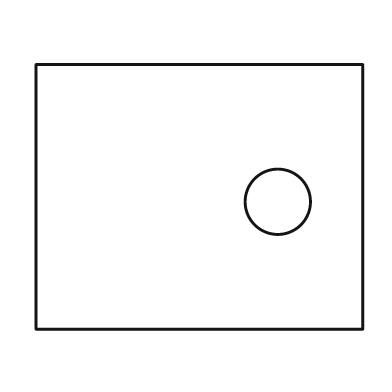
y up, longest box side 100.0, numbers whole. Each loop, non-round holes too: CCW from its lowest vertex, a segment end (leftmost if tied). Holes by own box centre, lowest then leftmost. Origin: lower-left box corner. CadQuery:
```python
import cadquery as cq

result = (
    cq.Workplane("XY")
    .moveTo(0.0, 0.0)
    .lineTo(100.0, 0.0)
    .lineTo(100.0, 81.0)
    .lineTo(0.0, 81.0)
    .close()
    .moveTo(74.0, 39.0)
    .circle(10.0)
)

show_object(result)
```